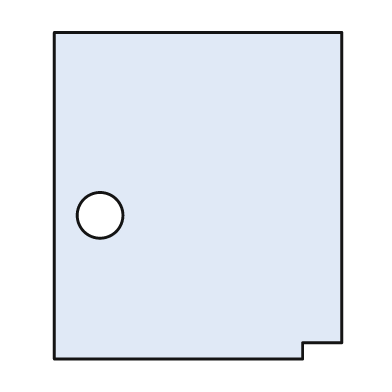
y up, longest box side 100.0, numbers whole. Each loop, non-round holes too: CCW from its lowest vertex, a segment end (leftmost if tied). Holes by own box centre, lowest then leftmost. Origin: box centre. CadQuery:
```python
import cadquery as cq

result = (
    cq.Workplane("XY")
    .moveTo(-44.0, -50.0)
    .lineTo(32.0, -50.0)
    .lineTo(32.0, -45.0)
    .lineTo(44.0, -45.0)
    .lineTo(44.0, 50.0)
    .lineTo(-44.0, 50.0)
    .close()
    .moveTo(-30.0, -6.0)
    .circle(7.0)
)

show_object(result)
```